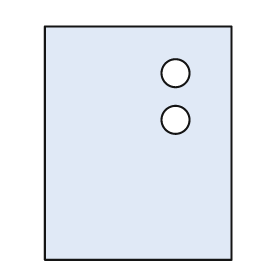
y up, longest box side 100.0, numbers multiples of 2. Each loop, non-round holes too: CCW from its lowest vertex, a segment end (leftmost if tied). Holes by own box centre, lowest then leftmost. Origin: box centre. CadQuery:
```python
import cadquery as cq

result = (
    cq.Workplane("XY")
    .moveTo(-40.0, -50.0)
    .lineTo(40.0, -50.0)
    .lineTo(40.0, 50.0)
    .lineTo(-40.0, 50.0)
    .close()
    .moveTo(16.0, 10.0)
    .circle(6.0)
    .moveTo(16.0, 30.0)
    .circle(6.0)
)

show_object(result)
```